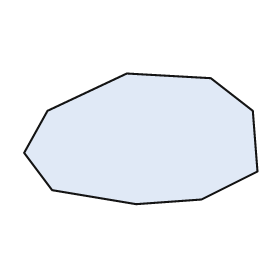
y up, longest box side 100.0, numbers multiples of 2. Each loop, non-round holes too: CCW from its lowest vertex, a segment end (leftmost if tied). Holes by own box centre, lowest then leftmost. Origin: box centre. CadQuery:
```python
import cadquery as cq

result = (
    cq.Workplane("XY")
    .moveTo(-2.0, -28.0)
    .lineTo(26.0, -26.0)
    .lineTo(50.0, -14.0)
    .lineTo(48.0, 12.0)
    .lineTo(30.0, 26.0)
    .lineTo(-6.0, 28.0)
    .lineTo(-40.0, 12.0)
    .lineTo(-50.0, -6.0)
    .lineTo(-38.0, -22.0)
    .close()
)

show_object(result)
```